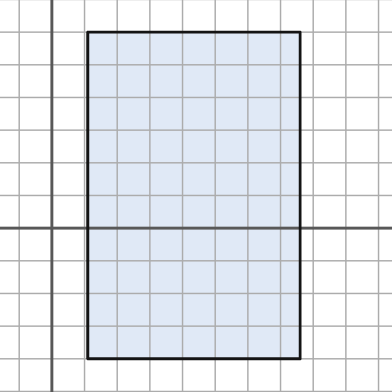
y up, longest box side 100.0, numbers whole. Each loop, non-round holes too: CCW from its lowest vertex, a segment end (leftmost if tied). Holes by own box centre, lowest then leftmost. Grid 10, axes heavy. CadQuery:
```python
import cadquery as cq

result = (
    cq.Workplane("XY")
    .moveTo(11.0, -40.0)
    .lineTo(76.0, -40.0)
    .lineTo(76.0, 60.0)
    .lineTo(11.0, 60.0)
    .close()
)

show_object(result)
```